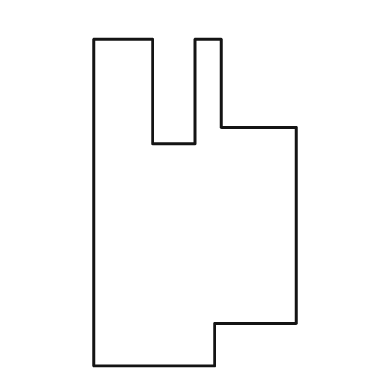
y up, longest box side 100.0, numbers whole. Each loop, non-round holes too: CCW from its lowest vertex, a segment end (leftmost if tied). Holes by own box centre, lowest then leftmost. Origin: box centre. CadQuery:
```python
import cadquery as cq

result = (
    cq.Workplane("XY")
    .moveTo(-31.0, -50.0)
    .lineTo(6.0, -50.0)
    .lineTo(6.0, -37.0)
    .lineTo(31.0, -37.0)
    .lineTo(31.0, 23.0)
    .lineTo(8.0, 23.0)
    .lineTo(8.0, 50.0)
    .lineTo(0.0, 50.0)
    .lineTo(0.0, 18.0)
    .lineTo(-13.0, 18.0)
    .lineTo(-13.0, 50.0)
    .lineTo(-31.0, 50.0)
    .close()
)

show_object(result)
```